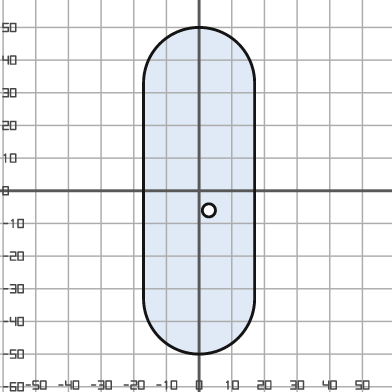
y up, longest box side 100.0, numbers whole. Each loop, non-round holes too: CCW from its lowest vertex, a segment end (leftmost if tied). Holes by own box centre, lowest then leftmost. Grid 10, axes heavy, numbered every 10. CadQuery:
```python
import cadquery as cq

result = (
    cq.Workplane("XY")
    .moveTo(-17.0, -33.0)
    .threePointArc((0.0, -50.0), (17.0, -33.0))
    .lineTo(17.0, 33.0)
    .threePointArc((0.0, 50.0), (-17.0, 33.0))
    .close()
    .moveTo(3.0, -6.0)
    .circle(2.0)
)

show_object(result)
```